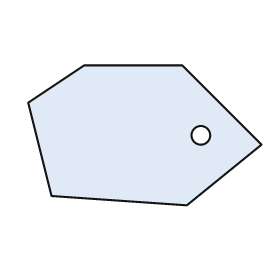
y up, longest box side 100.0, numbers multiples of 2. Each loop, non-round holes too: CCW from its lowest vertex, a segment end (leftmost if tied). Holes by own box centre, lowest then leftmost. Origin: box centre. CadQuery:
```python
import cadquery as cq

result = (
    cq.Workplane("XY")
    .moveTo(18.0, -30.0)
    .lineTo(50.0, -4.0)
    .lineTo(16.0, 30.0)
    .lineTo(-26.0, 30.0)
    .lineTo(-50.0, 14.0)
    .lineTo(-40.0, -26.0)
    .close()
    .moveTo(24.0, 0.0)
    .circle(4.0)
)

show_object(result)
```